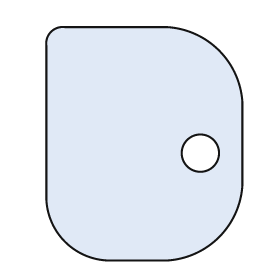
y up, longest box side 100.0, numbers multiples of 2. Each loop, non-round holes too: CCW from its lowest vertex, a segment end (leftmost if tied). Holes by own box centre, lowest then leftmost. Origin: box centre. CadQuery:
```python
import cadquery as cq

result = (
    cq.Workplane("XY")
    .moveTo(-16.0, -50.0)
    .lineTo(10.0, -50.0)
    .threePointArc((32.0, -40.0), (42.0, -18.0))
    .lineTo(42.0, 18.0)
    .threePointArc((32.0, 40.0), (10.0, 50.0))
    .lineTo(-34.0, 50.0)
    .threePointArc((-40.0, 48.0), (-42.0, 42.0))
    .lineTo(-42.0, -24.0)
    .threePointArc((-34.0, -42.0), (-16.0, -50.0))
    .close()
    .moveTo(24.0, -4.0)
    .circle(8.0)
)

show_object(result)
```